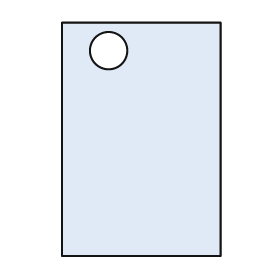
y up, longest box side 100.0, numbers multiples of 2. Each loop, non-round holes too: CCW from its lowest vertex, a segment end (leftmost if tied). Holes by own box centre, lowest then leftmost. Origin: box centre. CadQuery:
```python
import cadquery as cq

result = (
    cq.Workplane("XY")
    .moveTo(-34.0, -50.0)
    .lineTo(34.0, -50.0)
    .lineTo(34.0, 50.0)
    .lineTo(-34.0, 50.0)
    .close()
    .moveTo(-14.0, 38.0)
    .circle(8.0)
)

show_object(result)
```